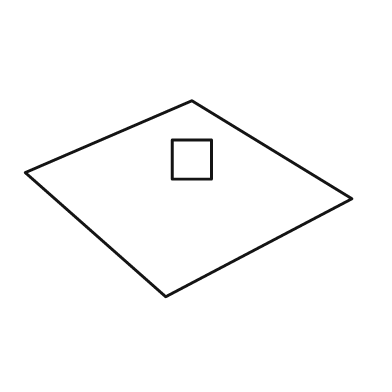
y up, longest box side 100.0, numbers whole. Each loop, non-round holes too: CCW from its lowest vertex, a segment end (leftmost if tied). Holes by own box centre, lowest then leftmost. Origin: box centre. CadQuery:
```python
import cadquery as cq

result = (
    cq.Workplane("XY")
    .moveTo(-7.0, -30.0)
    .lineTo(50.0, 0.0)
    .lineTo(1.0, 30.0)
    .lineTo(-50.0, 8.0)
    .close()
    .moveTo(-5.0, 6.0)
    .lineTo(7.0, 6.0)
    .lineTo(7.0, 18.0)
    .lineTo(-5.0, 18.0)
    .close()
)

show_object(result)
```